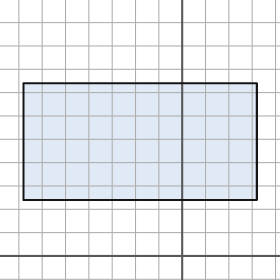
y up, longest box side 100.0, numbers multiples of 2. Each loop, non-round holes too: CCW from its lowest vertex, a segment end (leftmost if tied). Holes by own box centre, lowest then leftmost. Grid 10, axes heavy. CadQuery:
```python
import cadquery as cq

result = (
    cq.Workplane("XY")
    .moveTo(-68.0, 24.0)
    .lineTo(32.0, 24.0)
    .lineTo(32.0, 74.0)
    .lineTo(-68.0, 74.0)
    .close()
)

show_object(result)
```